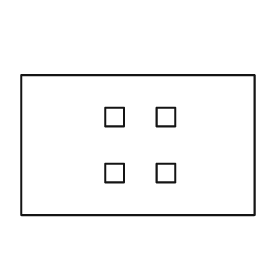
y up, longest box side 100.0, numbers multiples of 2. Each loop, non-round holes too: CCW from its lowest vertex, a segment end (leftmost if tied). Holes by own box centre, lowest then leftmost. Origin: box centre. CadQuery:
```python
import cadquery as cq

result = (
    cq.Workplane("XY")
    .moveTo(-50.0, -30.0)
    .lineTo(50.0, -30.0)
    .lineTo(50.0, 30.0)
    .lineTo(-50.0, 30.0)
    .close()
    .moveTo(-14.0, -16.0)
    .lineTo(-6.0, -16.0)
    .lineTo(-6.0, -8.0)
    .lineTo(-14.0, -8.0)
    .close()
    .moveTo(8.0, -16.0)
    .lineTo(16.0, -16.0)
    .lineTo(16.0, -8.0)
    .lineTo(8.0, -8.0)
    .close()
    .moveTo(-14.0, 8.0)
    .lineTo(-6.0, 8.0)
    .lineTo(-6.0, 16.0)
    .lineTo(-14.0, 16.0)
    .close()
    .moveTo(8.0, 8.0)
    .lineTo(16.0, 8.0)
    .lineTo(16.0, 16.0)
    .lineTo(8.0, 16.0)
    .close()
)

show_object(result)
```